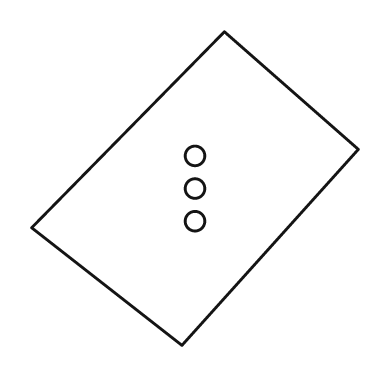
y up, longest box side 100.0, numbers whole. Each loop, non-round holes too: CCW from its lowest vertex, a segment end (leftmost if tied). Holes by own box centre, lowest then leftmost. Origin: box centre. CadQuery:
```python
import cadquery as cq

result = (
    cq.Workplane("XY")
    .moveTo(-4.0, -48.0)
    .lineTo(50.0, 12.0)
    .lineTo(9.0, 48.0)
    .lineTo(-50.0, -12.0)
    .close()
    .moveTo(0.0, -10.0)
    .circle(3.0)
    .moveTo(0.0, 0.0)
    .circle(3.0)
    .moveTo(0.0, 10.0)
    .circle(3.0)
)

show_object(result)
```